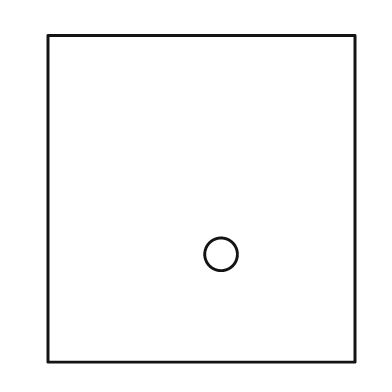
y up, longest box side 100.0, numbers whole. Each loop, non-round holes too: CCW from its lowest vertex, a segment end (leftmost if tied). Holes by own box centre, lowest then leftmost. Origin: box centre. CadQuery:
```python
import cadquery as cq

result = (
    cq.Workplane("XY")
    .moveTo(-47.0, -50.0)
    .lineTo(47.0, -50.0)
    .lineTo(47.0, 50.0)
    .lineTo(-47.0, 50.0)
    .close()
    .moveTo(6.0, -17.0)
    .circle(5.0)
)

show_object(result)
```